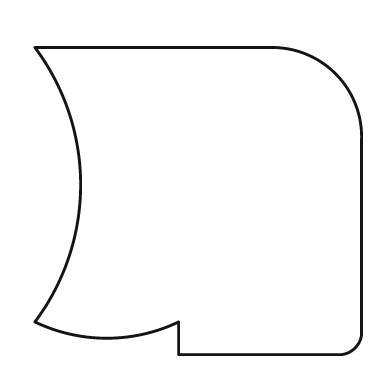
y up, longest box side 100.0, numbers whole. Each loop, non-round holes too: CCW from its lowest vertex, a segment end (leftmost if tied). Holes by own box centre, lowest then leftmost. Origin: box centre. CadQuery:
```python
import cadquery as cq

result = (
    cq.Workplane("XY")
    .moveTo(-6.0, -47.0)
    .lineTo(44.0, -47.0)
    .threePointArc((48.0, -45.0), (50.0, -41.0))
    .lineTo(50.0, 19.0)
    .threePointArc((42.0, 39.0), (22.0, 47.0))
    .lineTo(-50.0, 47.0)
    .threePointArc((-36.0, 5.0), (-50.0, -37.0))
    .threePointArc((-28.0, -42.0), (-6.0, -37.0))
    .close()
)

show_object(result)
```